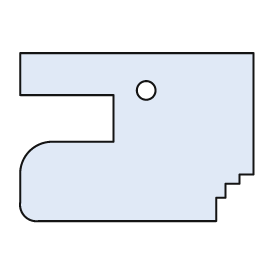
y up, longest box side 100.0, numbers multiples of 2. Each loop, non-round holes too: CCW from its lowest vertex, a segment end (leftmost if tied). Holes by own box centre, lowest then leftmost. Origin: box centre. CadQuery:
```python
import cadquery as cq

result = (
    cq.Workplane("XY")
    .moveTo(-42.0, -36.0)
    .lineTo(34.0, -36.0)
    .lineTo(34.0, -26.0)
    .lineTo(38.0, -26.0)
    .lineTo(38.0, -20.0)
    .lineTo(44.0, -20.0)
    .lineTo(44.0, -16.0)
    .lineTo(50.0, -16.0)
    .lineTo(50.0, 36.0)
    .lineTo(-50.0, 36.0)
    .lineTo(-50.0, 18.0)
    .lineTo(-10.0, 18.0)
    .lineTo(-10.0, -2.0)
    .lineTo(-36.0, -2.0)
    .threePointArc((-46.0, -6.0), (-50.0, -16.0))
    .lineTo(-50.0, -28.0)
    .threePointArc((-48.0, -34.0), (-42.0, -36.0))
    .close()
    .moveTo(4.0, 20.0)
    .circle(4.0)
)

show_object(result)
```